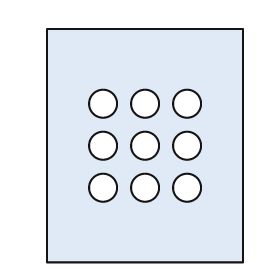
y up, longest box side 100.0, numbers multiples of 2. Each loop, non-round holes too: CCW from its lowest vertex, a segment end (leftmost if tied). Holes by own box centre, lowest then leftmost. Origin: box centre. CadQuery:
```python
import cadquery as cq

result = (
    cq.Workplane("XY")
    .moveTo(-42.0, -50.0)
    .lineTo(42.0, -50.0)
    .lineTo(42.0, 50.0)
    .lineTo(-42.0, 50.0)
    .close()
    .moveTo(-18.0, -18.0)
    .circle(6.0)
    .moveTo(0.0, -18.0)
    .circle(6.0)
    .moveTo(18.0, -18.0)
    .circle(6.0)
    .moveTo(-18.0, 0.0)
    .circle(6.0)
    .moveTo(0.0, 0.0)
    .circle(6.0)
    .moveTo(18.0, 0.0)
    .circle(6.0)
    .moveTo(-18.0, 18.0)
    .circle(6.0)
    .moveTo(0.0, 18.0)
    .circle(6.0)
    .moveTo(18.0, 18.0)
    .circle(6.0)
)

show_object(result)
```